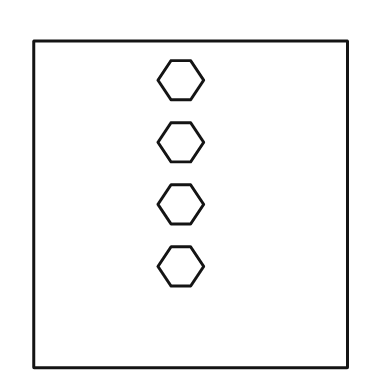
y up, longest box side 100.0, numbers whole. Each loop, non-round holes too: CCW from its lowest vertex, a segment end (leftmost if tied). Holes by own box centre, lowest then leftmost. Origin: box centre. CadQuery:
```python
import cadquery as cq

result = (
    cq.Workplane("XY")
    .moveTo(-48.0, -50.0)
    .lineTo(48.0, -50.0)
    .lineTo(48.0, 50.0)
    .lineTo(-48.0, 50.0)
    .close()
    .moveTo(-6.0, -25.0)
    .lineTo(0.0, -25.0)
    .lineTo(4.0, -19.0)
    .lineTo(0.0, -13.0)
    .lineTo(-6.0, -13.0)
    .lineTo(-10.0, -19.0)
    .close()
    .moveTo(-6.0, -6.0)
    .lineTo(0.0, -6.0)
    .lineTo(4.0, 0.0)
    .lineTo(0.0, 6.0)
    .lineTo(-6.0, 6.0)
    .lineTo(-10.0, 0.0)
    .close()
    .moveTo(-6.0, 13.0)
    .lineTo(0.0, 13.0)
    .lineTo(4.0, 19.0)
    .lineTo(0.0, 25.0)
    .lineTo(-6.0, 25.0)
    .lineTo(-10.0, 19.0)
    .close()
    .moveTo(-6.0, 32.0)
    .lineTo(0.0, 32.0)
    .lineTo(4.0, 38.0)
    .lineTo(0.0, 44.0)
    .lineTo(-6.0, 44.0)
    .lineTo(-10.0, 38.0)
    .close()
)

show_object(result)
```